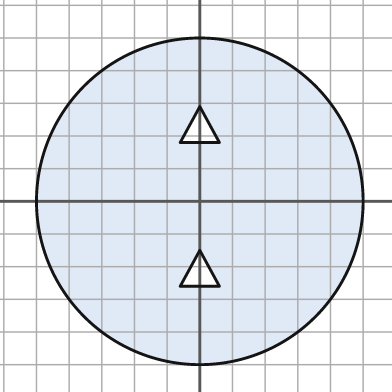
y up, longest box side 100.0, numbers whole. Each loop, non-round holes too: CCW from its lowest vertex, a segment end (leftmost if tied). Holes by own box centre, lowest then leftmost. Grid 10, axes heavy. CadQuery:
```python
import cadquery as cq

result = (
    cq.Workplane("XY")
    .moveTo(0.0, 0.0)
    .circle(50.0)
    .moveTo(-6.0, -26.0)
    .lineTo(6.0, -26.0)
    .lineTo(0.0, -15.0)
    .close()
    .moveTo(-6.0, 18.0)
    .lineTo(6.0, 18.0)
    .lineTo(0.0, 29.0)
    .close()
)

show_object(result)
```